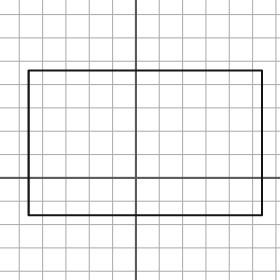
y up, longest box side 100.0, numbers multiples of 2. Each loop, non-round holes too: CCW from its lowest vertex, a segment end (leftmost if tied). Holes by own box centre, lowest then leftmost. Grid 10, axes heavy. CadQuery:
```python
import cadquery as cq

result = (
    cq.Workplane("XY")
    .moveTo(-46.0, -16.0)
    .lineTo(54.0, -16.0)
    .lineTo(54.0, 46.0)
    .lineTo(-46.0, 46.0)
    .close()
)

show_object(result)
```